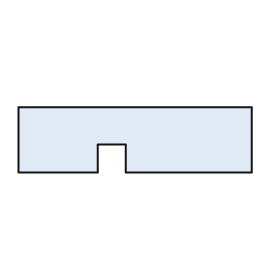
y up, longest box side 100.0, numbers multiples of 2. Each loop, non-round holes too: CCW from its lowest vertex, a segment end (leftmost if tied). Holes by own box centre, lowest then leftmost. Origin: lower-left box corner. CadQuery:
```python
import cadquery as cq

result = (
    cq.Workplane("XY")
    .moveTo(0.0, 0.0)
    .lineTo(34.0, 0.0)
    .lineTo(34.0, 12.0)
    .lineTo(46.0, 12.0)
    .lineTo(46.0, 0.0)
    .lineTo(100.0, 0.0)
    .lineTo(100.0, 28.0)
    .lineTo(0.0, 28.0)
    .close()
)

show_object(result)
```